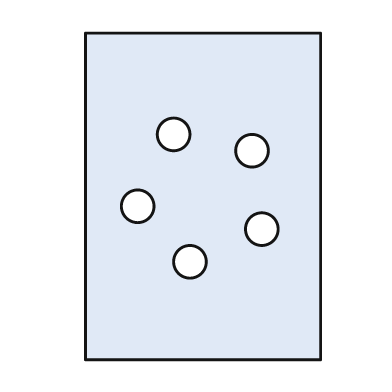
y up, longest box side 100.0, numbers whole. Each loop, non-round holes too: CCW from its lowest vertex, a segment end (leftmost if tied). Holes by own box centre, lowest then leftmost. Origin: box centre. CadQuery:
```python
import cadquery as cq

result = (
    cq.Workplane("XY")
    .moveTo(-36.0, -50.0)
    .lineTo(36.0, -50.0)
    .lineTo(36.0, 50.0)
    .lineTo(-36.0, 50.0)
    .close()
    .moveTo(-4.0, -20.0)
    .circle(5.0)
    .moveTo(18.0, -10.0)
    .circle(5.0)
    .moveTo(-20.0, -3.0)
    .circle(5.0)
    .moveTo(15.0, 14.0)
    .circle(5.0)
    .moveTo(-9.0, 19.0)
    .circle(5.0)
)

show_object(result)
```